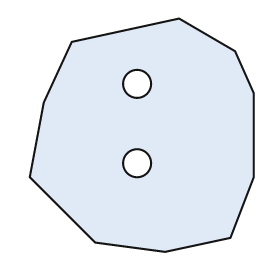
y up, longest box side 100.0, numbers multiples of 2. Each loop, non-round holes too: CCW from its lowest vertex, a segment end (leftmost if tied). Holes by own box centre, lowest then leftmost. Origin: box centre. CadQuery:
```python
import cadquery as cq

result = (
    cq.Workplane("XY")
    .moveTo(10.0, -50.0)
    .lineTo(38.0, -44.0)
    .lineTo(48.0, -18.0)
    .lineTo(48.0, 18.0)
    .lineTo(40.0, 36.0)
    .lineTo(16.0, 50.0)
    .lineTo(-30.0, 40.0)
    .lineTo(-42.0, 14.0)
    .lineTo(-48.0, -18.0)
    .lineTo(-20.0, -46.0)
    .close()
    .moveTo(-2.0, -12.0)
    .circle(6.0)
    .moveTo(-2.0, 22.0)
    .circle(6.0)
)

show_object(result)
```